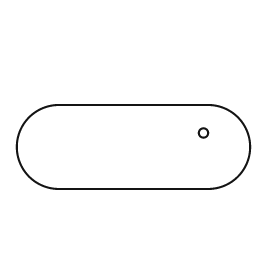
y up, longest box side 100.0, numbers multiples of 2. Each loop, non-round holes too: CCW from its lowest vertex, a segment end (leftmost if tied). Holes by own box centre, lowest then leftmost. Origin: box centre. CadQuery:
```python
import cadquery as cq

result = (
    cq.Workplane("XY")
    .moveTo(-32.0, -18.0)
    .lineTo(32.0, -18.0)
    .threePointArc((50.0, 0.0), (32.0, 18.0))
    .lineTo(-32.0, 18.0)
    .threePointArc((-50.0, 0.0), (-32.0, -18.0))
    .close()
    .moveTo(30.0, 6.0)
    .circle(2.0)
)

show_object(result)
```